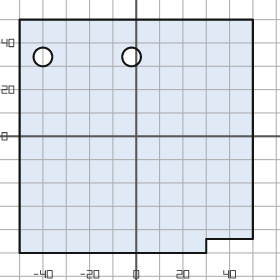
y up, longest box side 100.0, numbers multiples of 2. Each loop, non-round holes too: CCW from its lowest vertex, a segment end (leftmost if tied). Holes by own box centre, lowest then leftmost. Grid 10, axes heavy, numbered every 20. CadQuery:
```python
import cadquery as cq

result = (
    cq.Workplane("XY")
    .moveTo(-50.0, -50.0)
    .lineTo(30.0, -50.0)
    .lineTo(30.0, -44.0)
    .lineTo(50.0, -44.0)
    .lineTo(50.0, 50.0)
    .lineTo(-50.0, 50.0)
    .close()
    .moveTo(-40.0, 34.0)
    .circle(4.0)
    .moveTo(-2.0, 34.0)
    .circle(4.0)
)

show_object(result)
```